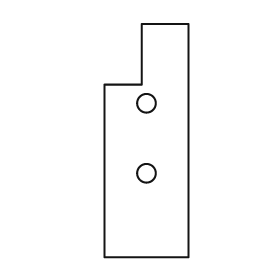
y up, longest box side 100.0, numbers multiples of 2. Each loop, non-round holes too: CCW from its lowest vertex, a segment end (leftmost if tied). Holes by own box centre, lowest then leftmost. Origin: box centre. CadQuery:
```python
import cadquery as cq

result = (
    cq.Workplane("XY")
    .moveTo(-18.0, -50.0)
    .lineTo(18.0, -50.0)
    .lineTo(18.0, 50.0)
    .lineTo(-2.0, 50.0)
    .lineTo(-2.0, 24.0)
    .lineTo(-18.0, 24.0)
    .close()
    .moveTo(0.0, -14.0)
    .circle(4.0)
    .moveTo(0.0, 16.0)
    .circle(4.0)
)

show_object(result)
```